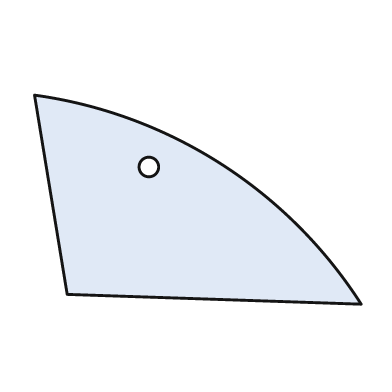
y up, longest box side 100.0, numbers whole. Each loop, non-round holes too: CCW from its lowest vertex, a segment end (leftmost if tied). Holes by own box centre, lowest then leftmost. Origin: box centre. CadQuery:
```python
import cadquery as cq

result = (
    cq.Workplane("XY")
    .moveTo(50.0, -32.0)
    .threePointArc((7.0, 11.0), (-50.0, 32.0))
    .lineTo(-40.0, -29.0)
    .close()
    .moveTo(-15.0, 10.0)
    .circle(3.0)
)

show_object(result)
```